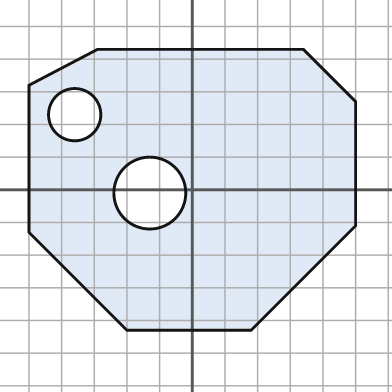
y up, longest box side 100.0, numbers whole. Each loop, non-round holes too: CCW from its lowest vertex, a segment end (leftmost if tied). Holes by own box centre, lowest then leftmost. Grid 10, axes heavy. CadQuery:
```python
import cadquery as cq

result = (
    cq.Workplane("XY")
    .moveTo(-20.0, -43.0)
    .lineTo(18.0, -43.0)
    .lineTo(50.0, -11.0)
    .lineTo(50.0, 27.0)
    .lineTo(34.0, 43.0)
    .lineTo(-29.0, 43.0)
    .lineTo(-50.0, 32.0)
    .lineTo(-50.0, -13.0)
    .close()
    .moveTo(-13.0, -1.0)
    .circle(11.0)
    .moveTo(-36.0, 23.0)
    .circle(8.0)
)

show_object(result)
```